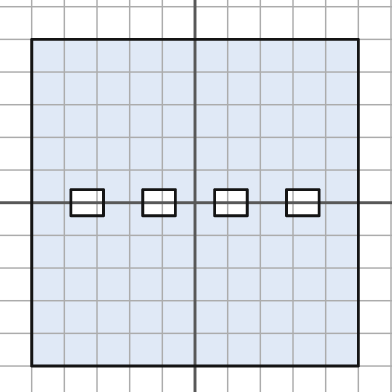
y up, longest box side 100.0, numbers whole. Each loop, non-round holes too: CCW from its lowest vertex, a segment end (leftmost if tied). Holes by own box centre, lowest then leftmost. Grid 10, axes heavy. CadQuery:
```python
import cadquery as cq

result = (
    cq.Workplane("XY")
    .moveTo(-50.0, -50.0)
    .lineTo(50.0, -50.0)
    .lineTo(50.0, 50.0)
    .lineTo(-50.0, 50.0)
    .close()
    .moveTo(-38.0, -4.0)
    .lineTo(-28.0, -4.0)
    .lineTo(-28.0, 4.0)
    .lineTo(-38.0, 4.0)
    .close()
    .moveTo(-16.0, -4.0)
    .lineTo(-6.0, -4.0)
    .lineTo(-6.0, 4.0)
    .lineTo(-16.0, 4.0)
    .close()
    .moveTo(6.0, -4.0)
    .lineTo(16.0, -4.0)
    .lineTo(16.0, 4.0)
    .lineTo(6.0, 4.0)
    .close()
    .moveTo(28.0, -4.0)
    .lineTo(38.0, -4.0)
    .lineTo(38.0, 4.0)
    .lineTo(28.0, 4.0)
    .close()
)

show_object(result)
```